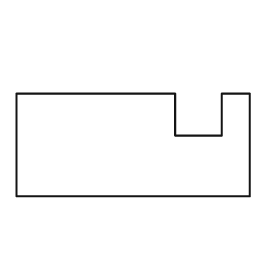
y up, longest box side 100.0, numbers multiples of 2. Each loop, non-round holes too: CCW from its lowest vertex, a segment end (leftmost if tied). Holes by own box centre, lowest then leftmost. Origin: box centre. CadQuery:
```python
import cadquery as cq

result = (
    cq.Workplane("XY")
    .moveTo(-50.0, -22.0)
    .lineTo(50.0, -22.0)
    .lineTo(50.0, 22.0)
    .lineTo(38.0, 22.0)
    .lineTo(38.0, 4.0)
    .lineTo(18.0, 4.0)
    .lineTo(18.0, 22.0)
    .lineTo(-50.0, 22.0)
    .close()
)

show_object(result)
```